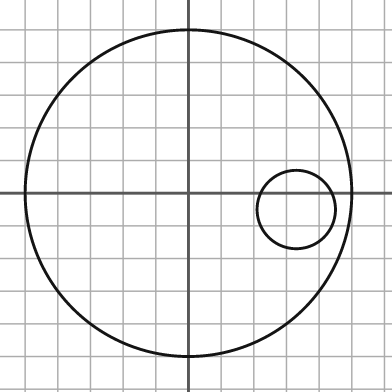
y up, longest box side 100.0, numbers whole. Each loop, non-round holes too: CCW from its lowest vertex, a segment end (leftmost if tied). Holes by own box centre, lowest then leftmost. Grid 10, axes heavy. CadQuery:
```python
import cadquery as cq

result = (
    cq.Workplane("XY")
    .moveTo(0.0, 0.0)
    .circle(50.0)
    .moveTo(33.0, -5.0)
    .circle(12.0)
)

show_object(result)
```